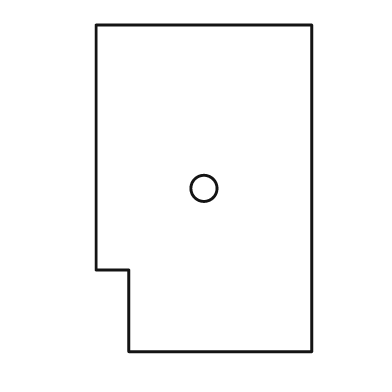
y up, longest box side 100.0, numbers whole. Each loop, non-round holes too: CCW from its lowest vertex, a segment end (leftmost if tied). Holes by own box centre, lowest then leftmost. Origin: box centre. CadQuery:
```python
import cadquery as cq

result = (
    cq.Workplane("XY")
    .moveTo(-23.0, -50.0)
    .lineTo(33.0, -50.0)
    .lineTo(33.0, 50.0)
    .lineTo(-33.0, 50.0)
    .lineTo(-33.0, -25.0)
    .lineTo(-23.0, -25.0)
    .close()
    .moveTo(0.0, 0.0)
    .circle(4.0)
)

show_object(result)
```